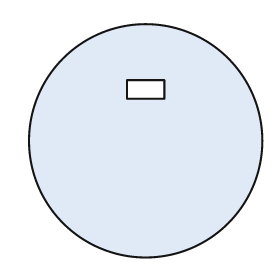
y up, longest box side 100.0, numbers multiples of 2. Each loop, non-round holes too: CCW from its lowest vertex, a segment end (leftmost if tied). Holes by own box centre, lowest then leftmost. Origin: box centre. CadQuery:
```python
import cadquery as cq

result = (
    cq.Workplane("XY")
    .moveTo(0.0, 0.0)
    .circle(50.0)
    .moveTo(-8.0, 18.0)
    .lineTo(8.0, 18.0)
    .lineTo(8.0, 26.0)
    .lineTo(-8.0, 26.0)
    .close()
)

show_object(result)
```